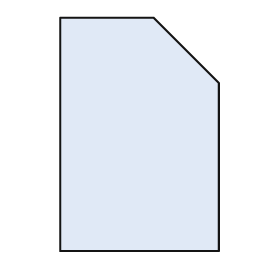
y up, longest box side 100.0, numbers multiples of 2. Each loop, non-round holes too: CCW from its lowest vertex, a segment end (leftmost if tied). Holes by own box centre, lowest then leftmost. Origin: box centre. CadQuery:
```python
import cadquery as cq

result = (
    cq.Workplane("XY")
    .moveTo(-34.0, -50.0)
    .lineTo(34.0, -50.0)
    .lineTo(34.0, 22.0)
    .lineTo(6.0, 50.0)
    .lineTo(-34.0, 50.0)
    .close()
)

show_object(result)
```